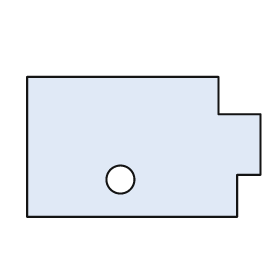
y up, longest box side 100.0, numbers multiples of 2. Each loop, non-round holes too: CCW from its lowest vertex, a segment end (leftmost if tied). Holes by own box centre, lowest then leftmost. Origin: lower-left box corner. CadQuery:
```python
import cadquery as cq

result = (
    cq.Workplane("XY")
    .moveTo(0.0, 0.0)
    .lineTo(90.0, 0.0)
    .lineTo(90.0, 18.0)
    .lineTo(100.0, 18.0)
    .lineTo(100.0, 44.0)
    .lineTo(82.0, 44.0)
    .lineTo(82.0, 60.0)
    .lineTo(0.0, 60.0)
    .close()
    .moveTo(40.0, 16.0)
    .circle(6.0)
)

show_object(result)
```